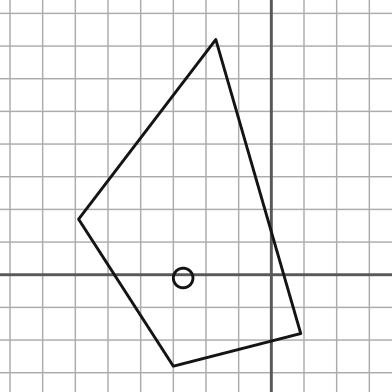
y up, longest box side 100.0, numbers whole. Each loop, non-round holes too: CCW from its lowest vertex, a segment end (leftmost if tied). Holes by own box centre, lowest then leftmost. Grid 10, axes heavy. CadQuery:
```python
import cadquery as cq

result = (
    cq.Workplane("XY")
    .moveTo(-30.0, -28.0)
    .lineTo(9.0, -18.0)
    .lineTo(-17.0, 72.0)
    .lineTo(-59.0, 17.0)
    .close()
    .moveTo(-27.0, -1.0)
    .circle(3.0)
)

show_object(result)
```